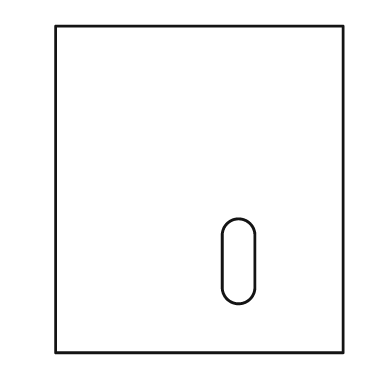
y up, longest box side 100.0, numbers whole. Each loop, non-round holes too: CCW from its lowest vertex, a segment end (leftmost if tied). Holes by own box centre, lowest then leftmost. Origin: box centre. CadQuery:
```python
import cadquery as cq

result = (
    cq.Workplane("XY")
    .moveTo(-44.0, -50.0)
    .lineTo(44.0, -50.0)
    .lineTo(44.0, 50.0)
    .lineTo(-44.0, 50.0)
    .close()
    .moveTo(7.0, -30.0)
    .threePointArc((12.0, -35.0), (17.0, -30.0))
    .lineTo(17.0, -14.0)
    .threePointArc((12.0, -9.0), (7.0, -14.0))
    .close()
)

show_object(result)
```